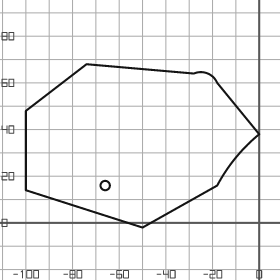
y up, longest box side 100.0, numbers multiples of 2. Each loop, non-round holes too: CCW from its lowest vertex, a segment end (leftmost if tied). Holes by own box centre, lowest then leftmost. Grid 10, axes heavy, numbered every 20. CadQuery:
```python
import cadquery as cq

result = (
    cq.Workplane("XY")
    .moveTo(-50.0, -2.0)
    .lineTo(-18.0, 16.0)
    .threePointArc((-10.0, 28.0), (0.0, 38.0))
    .lineTo(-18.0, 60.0)
    .threePointArc((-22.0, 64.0), (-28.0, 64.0))
    .lineTo(-74.0, 68.0)
    .lineTo(-100.0, 48.0)
    .lineTo(-100.0, 14.0)
    .close()
    .moveTo(-66.0, 16.0)
    .circle(2.0)
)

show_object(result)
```